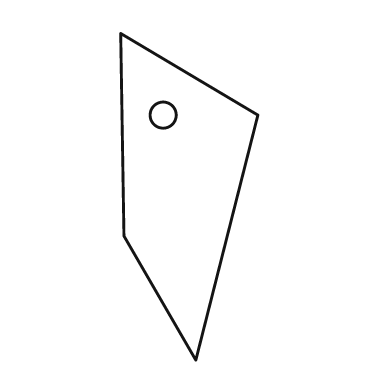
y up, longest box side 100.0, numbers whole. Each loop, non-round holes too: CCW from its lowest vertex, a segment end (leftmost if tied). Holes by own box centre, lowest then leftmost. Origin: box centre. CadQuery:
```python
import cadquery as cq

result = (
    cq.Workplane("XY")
    .moveTo(2.0, -50.0)
    .lineTo(21.0, 25.0)
    .lineTo(-21.0, 50.0)
    .lineTo(-20.0, -12.0)
    .close()
    .moveTo(-8.0, 25.0)
    .circle(4.0)
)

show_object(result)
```